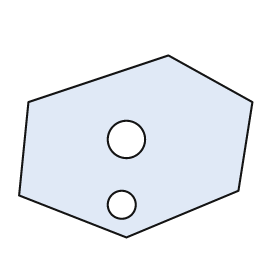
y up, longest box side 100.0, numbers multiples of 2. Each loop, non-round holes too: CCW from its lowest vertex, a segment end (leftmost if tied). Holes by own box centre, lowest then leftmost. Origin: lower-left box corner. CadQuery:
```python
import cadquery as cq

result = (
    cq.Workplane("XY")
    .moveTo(46.0, 0.0)
    .lineTo(94.0, 20.0)
    .lineTo(100.0, 58.0)
    .lineTo(64.0, 78.0)
    .lineTo(4.0, 58.0)
    .lineTo(0.0, 18.0)
    .close()
    .moveTo(44.0, 14.0)
    .circle(6.0)
    .moveTo(46.0, 42.0)
    .circle(8.0)
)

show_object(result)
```